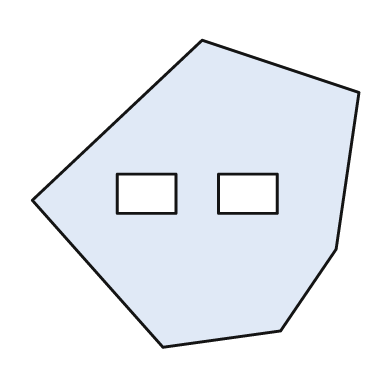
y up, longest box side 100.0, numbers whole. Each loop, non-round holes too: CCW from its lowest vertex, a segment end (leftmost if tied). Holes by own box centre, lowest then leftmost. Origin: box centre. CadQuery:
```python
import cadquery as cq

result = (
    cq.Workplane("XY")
    .moveTo(-10.0, -47.0)
    .lineTo(26.0, -42.0)
    .lineTo(43.0, -17.0)
    .lineTo(50.0, 31.0)
    .lineTo(2.0, 47.0)
    .lineTo(-50.0, -2.0)
    .close()
    .moveTo(-24.0, -6.0)
    .lineTo(-6.0, -6.0)
    .lineTo(-6.0, 6.0)
    .lineTo(-24.0, 6.0)
    .close()
    .moveTo(7.0, -6.0)
    .lineTo(25.0, -6.0)
    .lineTo(25.0, 6.0)
    .lineTo(7.0, 6.0)
    .close()
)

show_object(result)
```